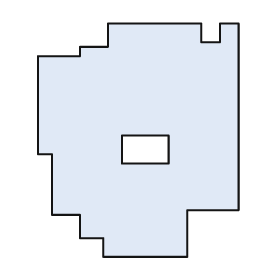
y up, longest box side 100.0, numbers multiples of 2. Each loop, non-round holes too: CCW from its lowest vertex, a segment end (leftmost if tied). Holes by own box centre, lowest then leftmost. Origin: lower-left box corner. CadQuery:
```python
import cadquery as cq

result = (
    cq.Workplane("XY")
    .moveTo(28.0, 0.0)
    .lineTo(64.0, 0.0)
    .lineTo(64.0, 20.0)
    .lineTo(86.0, 20.0)
    .lineTo(86.0, 100.0)
    .lineTo(78.0, 100.0)
    .lineTo(78.0, 92.0)
    .lineTo(70.0, 92.0)
    .lineTo(70.0, 100.0)
    .lineTo(30.0, 100.0)
    .lineTo(30.0, 90.0)
    .lineTo(18.0, 90.0)
    .lineTo(18.0, 86.0)
    .lineTo(0.0, 86.0)
    .lineTo(0.0, 44.0)
    .lineTo(6.0, 44.0)
    .lineTo(6.0, 18.0)
    .lineTo(18.0, 18.0)
    .lineTo(18.0, 8.0)
    .lineTo(28.0, 8.0)
    .close()
    .moveTo(36.0, 40.0)
    .lineTo(56.0, 40.0)
    .lineTo(56.0, 52.0)
    .lineTo(36.0, 52.0)
    .close()
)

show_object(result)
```